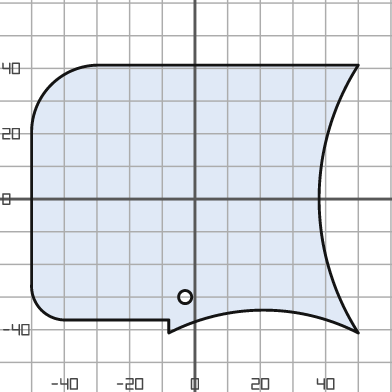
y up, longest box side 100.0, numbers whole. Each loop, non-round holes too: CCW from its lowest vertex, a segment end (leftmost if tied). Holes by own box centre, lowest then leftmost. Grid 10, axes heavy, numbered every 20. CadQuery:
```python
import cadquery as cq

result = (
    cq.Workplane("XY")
    .moveTo(-8.0, -41.0)
    .threePointArc((21.0, -34.0), (50.0, -41.0))
    .threePointArc((38.0, 0.0), (50.0, 41.0))
    .lineTo(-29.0, 41.0)
    .threePointArc((-44.0, 35.0), (-50.0, 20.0))
    .lineTo(-50.0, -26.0)
    .threePointArc((-47.0, -34.0), (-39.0, -37.0))
    .lineTo(-8.0, -37.0)
    .close()
    .moveTo(-3.0, -30.0)
    .circle(2.0)
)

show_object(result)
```